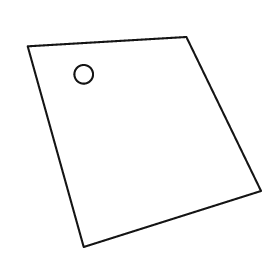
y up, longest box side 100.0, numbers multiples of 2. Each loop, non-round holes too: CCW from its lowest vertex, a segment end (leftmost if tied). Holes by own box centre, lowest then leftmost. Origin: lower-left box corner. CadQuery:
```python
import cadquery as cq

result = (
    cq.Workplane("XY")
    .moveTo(24.0, 0.0)
    .lineTo(100.0, 24.0)
    .lineTo(68.0, 90.0)
    .lineTo(0.0, 86.0)
    .close()
    .moveTo(24.0, 74.0)
    .circle(4.0)
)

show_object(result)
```